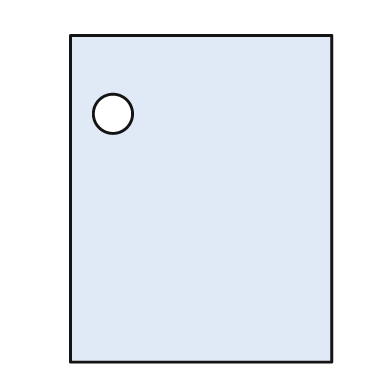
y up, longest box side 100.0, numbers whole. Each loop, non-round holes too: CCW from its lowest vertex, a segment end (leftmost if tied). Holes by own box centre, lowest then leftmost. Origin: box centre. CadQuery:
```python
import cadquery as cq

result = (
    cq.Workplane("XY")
    .moveTo(-40.0, -50.0)
    .lineTo(40.0, -50.0)
    .lineTo(40.0, 50.0)
    .lineTo(-40.0, 50.0)
    .close()
    .moveTo(-27.0, 26.0)
    .circle(6.0)
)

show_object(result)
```